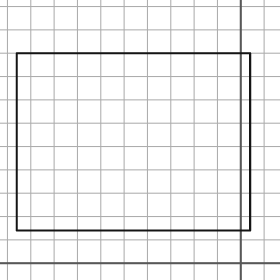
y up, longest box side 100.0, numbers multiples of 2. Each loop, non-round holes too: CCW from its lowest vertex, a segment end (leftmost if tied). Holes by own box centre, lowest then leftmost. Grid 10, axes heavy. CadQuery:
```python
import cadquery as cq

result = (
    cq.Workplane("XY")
    .moveTo(-96.0, 14.0)
    .lineTo(4.0, 14.0)
    .lineTo(4.0, 90.0)
    .lineTo(-96.0, 90.0)
    .close()
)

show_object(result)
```